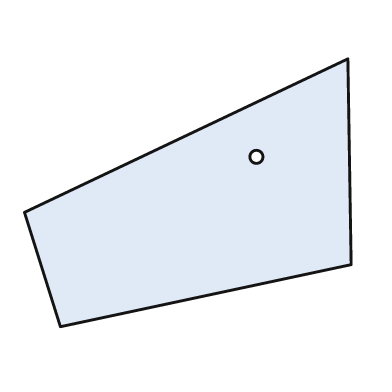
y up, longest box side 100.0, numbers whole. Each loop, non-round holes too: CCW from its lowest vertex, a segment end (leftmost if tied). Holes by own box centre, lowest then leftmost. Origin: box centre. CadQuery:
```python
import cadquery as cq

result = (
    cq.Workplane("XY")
    .moveTo(-39.0, -41.0)
    .lineTo(50.0, -22.0)
    .lineTo(49.0, 41.0)
    .lineTo(-50.0, -6.0)
    .close()
    .moveTo(21.0, 11.0)
    .circle(2.0)
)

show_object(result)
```